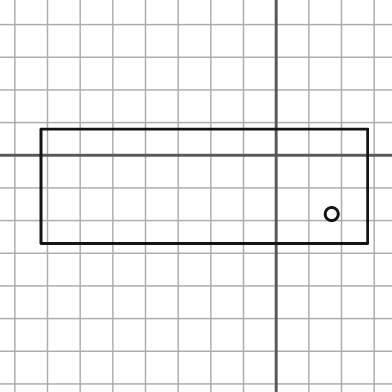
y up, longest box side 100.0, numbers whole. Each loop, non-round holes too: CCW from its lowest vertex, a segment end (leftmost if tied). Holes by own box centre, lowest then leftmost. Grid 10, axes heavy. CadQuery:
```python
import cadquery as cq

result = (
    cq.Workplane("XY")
    .moveTo(-72.0, -27.0)
    .lineTo(28.0, -27.0)
    .lineTo(28.0, 8.0)
    .lineTo(-72.0, 8.0)
    .close()
    .moveTo(17.0, -18.0)
    .circle(2.0)
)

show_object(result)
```